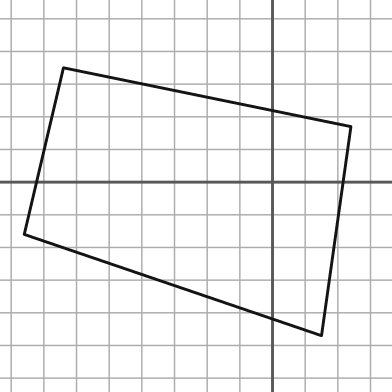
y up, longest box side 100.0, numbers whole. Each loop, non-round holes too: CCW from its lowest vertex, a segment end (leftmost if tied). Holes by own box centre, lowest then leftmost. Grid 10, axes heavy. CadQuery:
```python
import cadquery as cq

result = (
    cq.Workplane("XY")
    .moveTo(15.0, -47.0)
    .lineTo(24.0, 17.0)
    .lineTo(-64.0, 35.0)
    .lineTo(-76.0, -16.0)
    .close()
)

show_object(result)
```